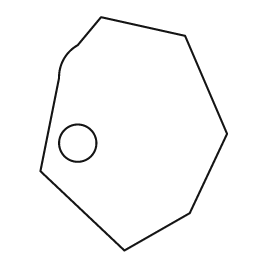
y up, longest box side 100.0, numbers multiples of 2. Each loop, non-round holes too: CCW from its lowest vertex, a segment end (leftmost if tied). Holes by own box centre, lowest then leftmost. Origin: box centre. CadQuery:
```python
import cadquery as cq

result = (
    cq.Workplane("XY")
    .moveTo(-4.0, -50.0)
    .lineTo(24.0, -34.0)
    .lineTo(40.0, 0.0)
    .lineTo(22.0, 42.0)
    .lineTo(-14.0, 50.0)
    .lineTo(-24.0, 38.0)
    .threePointArc((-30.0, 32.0), (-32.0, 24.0))
    .lineTo(-40.0, -16.0)
    .close()
    .moveTo(-24.0, -4.0)
    .circle(8.0)
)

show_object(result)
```